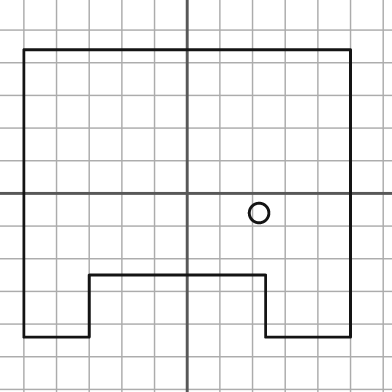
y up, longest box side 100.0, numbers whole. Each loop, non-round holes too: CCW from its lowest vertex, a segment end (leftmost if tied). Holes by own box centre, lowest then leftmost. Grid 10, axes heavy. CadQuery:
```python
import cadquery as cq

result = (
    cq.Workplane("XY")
    .moveTo(-50.0, -44.0)
    .lineTo(-30.0, -44.0)
    .lineTo(-30.0, -25.0)
    .lineTo(24.0, -25.0)
    .lineTo(24.0, -44.0)
    .lineTo(50.0, -44.0)
    .lineTo(50.0, 44.0)
    .lineTo(-50.0, 44.0)
    .close()
    .moveTo(22.0, -6.0)
    .circle(3.0)
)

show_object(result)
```